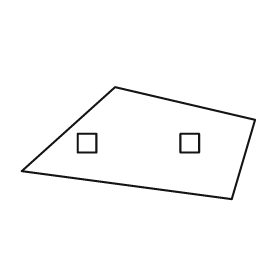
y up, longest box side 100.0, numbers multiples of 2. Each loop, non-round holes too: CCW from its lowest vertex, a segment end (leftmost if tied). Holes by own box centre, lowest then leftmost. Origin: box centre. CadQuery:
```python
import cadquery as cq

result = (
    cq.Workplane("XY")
    .moveTo(40.0, -24.0)
    .lineTo(50.0, 10.0)
    .lineTo(-10.0, 24.0)
    .lineTo(-50.0, -12.0)
    .close()
    .moveTo(-26.0, -4.0)
    .lineTo(-18.0, -4.0)
    .lineTo(-18.0, 4.0)
    .lineTo(-26.0, 4.0)
    .close()
    .moveTo(18.0, -4.0)
    .lineTo(26.0, -4.0)
    .lineTo(26.0, 4.0)
    .lineTo(18.0, 4.0)
    .close()
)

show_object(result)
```